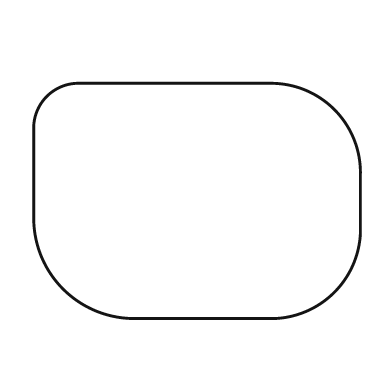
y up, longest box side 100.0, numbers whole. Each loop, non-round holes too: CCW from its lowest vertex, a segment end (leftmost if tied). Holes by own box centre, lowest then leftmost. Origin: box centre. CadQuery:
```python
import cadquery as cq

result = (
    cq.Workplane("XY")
    .moveTo(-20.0, -36.0)
    .lineTo(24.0, -36.0)
    .threePointArc((42.0, -28.0), (50.0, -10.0))
    .lineTo(50.0, 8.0)
    .threePointArc((42.0, 28.0), (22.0, 36.0))
    .lineTo(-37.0, 36.0)
    .threePointArc((-46.0, 32.0), (-50.0, 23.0))
    .lineTo(-50.0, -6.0)
    .threePointArc((-41.0, -27.0), (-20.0, -36.0))
    .close()
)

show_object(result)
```